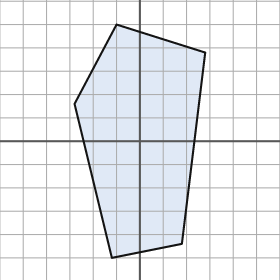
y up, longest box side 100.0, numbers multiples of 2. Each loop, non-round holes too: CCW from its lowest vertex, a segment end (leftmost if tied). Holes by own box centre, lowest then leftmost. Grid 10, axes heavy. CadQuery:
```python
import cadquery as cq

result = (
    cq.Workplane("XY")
    .moveTo(-12.0, -50.0)
    .lineTo(18.0, -44.0)
    .lineTo(28.0, 38.0)
    .lineTo(-10.0, 50.0)
    .lineTo(-28.0, 16.0)
    .close()
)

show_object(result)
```